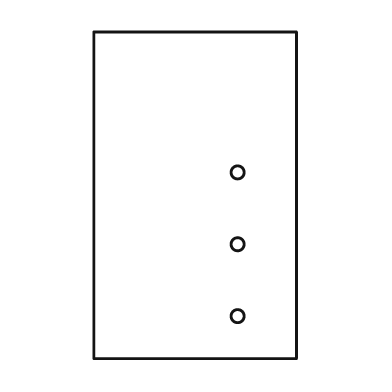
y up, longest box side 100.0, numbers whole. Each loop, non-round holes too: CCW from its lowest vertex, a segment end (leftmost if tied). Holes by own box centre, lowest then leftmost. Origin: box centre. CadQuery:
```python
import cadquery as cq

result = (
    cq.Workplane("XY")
    .moveTo(-31.0, -50.0)
    .lineTo(31.0, -50.0)
    .lineTo(31.0, 50.0)
    .lineTo(-31.0, 50.0)
    .close()
    .moveTo(13.0, -37.0)
    .circle(2.0)
    .moveTo(13.0, -15.0)
    .circle(2.0)
    .moveTo(13.0, 7.0)
    .circle(2.0)
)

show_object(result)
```